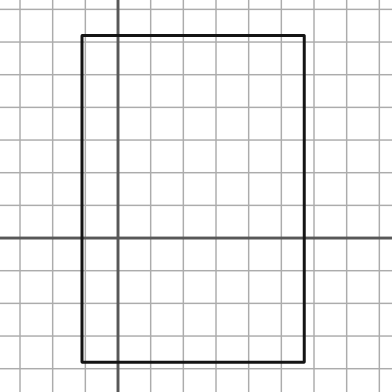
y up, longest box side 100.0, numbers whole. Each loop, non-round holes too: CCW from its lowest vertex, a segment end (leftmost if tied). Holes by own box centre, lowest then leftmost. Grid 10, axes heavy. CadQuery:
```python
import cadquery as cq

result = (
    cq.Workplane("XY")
    .moveTo(-11.0, -38.0)
    .lineTo(57.0, -38.0)
    .lineTo(57.0, 62.0)
    .lineTo(-11.0, 62.0)
    .close()
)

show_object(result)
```